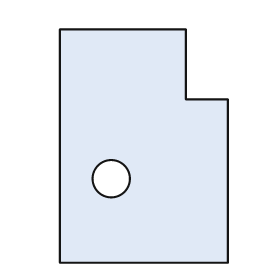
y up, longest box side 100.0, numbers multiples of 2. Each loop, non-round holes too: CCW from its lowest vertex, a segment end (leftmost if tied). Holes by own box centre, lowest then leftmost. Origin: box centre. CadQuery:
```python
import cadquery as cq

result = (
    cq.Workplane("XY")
    .moveTo(-36.0, -50.0)
    .lineTo(36.0, -50.0)
    .lineTo(36.0, 20.0)
    .lineTo(18.0, 20.0)
    .lineTo(18.0, 50.0)
    .lineTo(-36.0, 50.0)
    .close()
    .moveTo(-14.0, -14.0)
    .circle(8.0)
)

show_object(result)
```